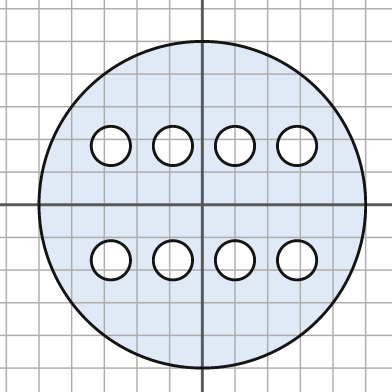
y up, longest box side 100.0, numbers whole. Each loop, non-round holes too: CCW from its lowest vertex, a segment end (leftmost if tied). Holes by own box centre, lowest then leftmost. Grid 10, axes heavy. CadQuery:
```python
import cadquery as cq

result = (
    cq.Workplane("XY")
    .moveTo(0.0, 0.0)
    .circle(50.0)
    .moveTo(-28.0, -17.0)
    .circle(6.0)
    .moveTo(-9.0, -17.0)
    .circle(6.0)
    .moveTo(10.0, -17.0)
    .circle(6.0)
    .moveTo(29.0, -17.0)
    .circle(6.0)
    .moveTo(-28.0, 18.0)
    .circle(6.0)
    .moveTo(-9.0, 18.0)
    .circle(6.0)
    .moveTo(10.0, 18.0)
    .circle(6.0)
    .moveTo(29.0, 18.0)
    .circle(6.0)
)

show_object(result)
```